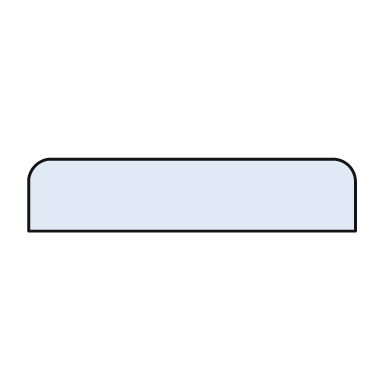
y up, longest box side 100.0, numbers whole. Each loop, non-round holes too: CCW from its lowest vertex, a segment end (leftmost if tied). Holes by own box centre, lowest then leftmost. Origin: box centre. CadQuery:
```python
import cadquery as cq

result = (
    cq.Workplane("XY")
    .moveTo(-50.0, -11.0)
    .lineTo(50.0, -11.0)
    .lineTo(50.0, 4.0)
    .threePointArc((48.0, 9.0), (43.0, 11.0))
    .lineTo(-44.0, 11.0)
    .threePointArc((-48.0, 9.0), (-50.0, 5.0))
    .close()
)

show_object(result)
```